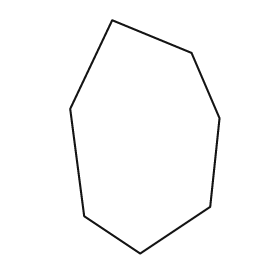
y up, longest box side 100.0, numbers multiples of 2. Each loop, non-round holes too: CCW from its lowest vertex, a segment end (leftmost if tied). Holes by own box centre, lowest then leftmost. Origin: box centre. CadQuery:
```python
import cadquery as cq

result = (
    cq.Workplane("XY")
    .moveTo(-2.0, -50.0)
    .lineTo(28.0, -30.0)
    .lineTo(32.0, 8.0)
    .lineTo(20.0, 36.0)
    .lineTo(-14.0, 50.0)
    .lineTo(-32.0, 12.0)
    .lineTo(-26.0, -34.0)
    .close()
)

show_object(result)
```